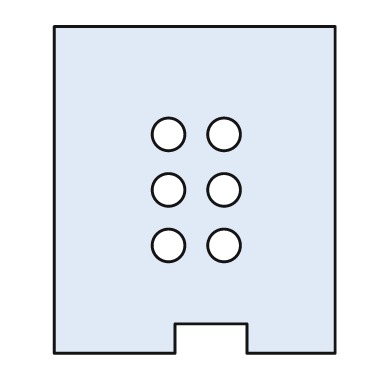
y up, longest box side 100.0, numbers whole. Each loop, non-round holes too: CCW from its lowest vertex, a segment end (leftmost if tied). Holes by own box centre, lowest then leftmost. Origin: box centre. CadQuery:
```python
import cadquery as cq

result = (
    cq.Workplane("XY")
    .moveTo(-43.0, -50.0)
    .lineTo(-6.0, -50.0)
    .lineTo(-6.0, -41.0)
    .lineTo(16.0, -41.0)
    .lineTo(16.0, -50.0)
    .lineTo(43.0, -50.0)
    .lineTo(43.0, 50.0)
    .lineTo(-43.0, 50.0)
    .close()
    .moveTo(-8.0, -17.0)
    .circle(5.0)
    .moveTo(9.0, -17.0)
    .circle(5.0)
    .moveTo(-8.0, 0.0)
    .circle(5.0)
    .moveTo(9.0, 0.0)
    .circle(5.0)
    .moveTo(-8.0, 17.0)
    .circle(5.0)
    .moveTo(9.0, 17.0)
    .circle(5.0)
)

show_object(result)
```